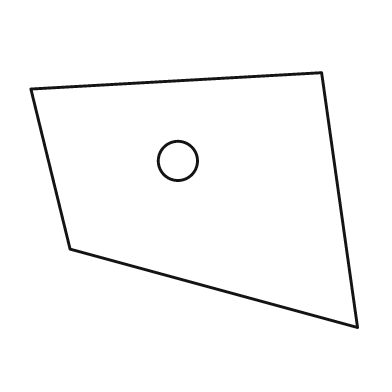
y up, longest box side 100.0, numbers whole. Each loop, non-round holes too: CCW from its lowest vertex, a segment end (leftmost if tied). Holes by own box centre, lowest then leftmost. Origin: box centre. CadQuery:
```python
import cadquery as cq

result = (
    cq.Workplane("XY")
    .moveTo(50.0, -39.0)
    .lineTo(39.0, 39.0)
    .lineTo(-50.0, 34.0)
    .lineTo(-38.0, -15.0)
    .close()
    .moveTo(-5.0, 12.0)
    .circle(6.0)
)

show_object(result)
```